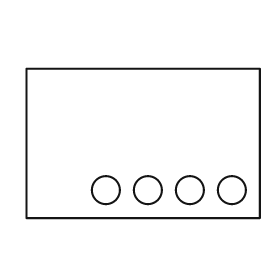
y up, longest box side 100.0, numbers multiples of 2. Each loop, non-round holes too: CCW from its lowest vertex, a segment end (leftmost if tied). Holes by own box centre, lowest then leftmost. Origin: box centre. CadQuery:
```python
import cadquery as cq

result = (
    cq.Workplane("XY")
    .moveTo(-50.0, -32.0)
    .lineTo(50.0, -32.0)
    .lineTo(50.0, 32.0)
    .lineTo(-50.0, 32.0)
    .close()
    .moveTo(-16.0, -20.0)
    .circle(6.0)
    .moveTo(2.0, -20.0)
    .circle(6.0)
    .moveTo(20.0, -20.0)
    .circle(6.0)
    .moveTo(38.0, -20.0)
    .circle(6.0)
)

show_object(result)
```